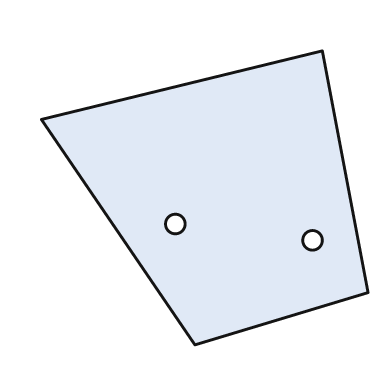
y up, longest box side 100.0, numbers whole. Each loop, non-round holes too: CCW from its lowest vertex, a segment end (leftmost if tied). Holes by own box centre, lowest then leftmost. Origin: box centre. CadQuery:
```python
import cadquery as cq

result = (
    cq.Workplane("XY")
    .moveTo(-3.0, -45.0)
    .lineTo(50.0, -29.0)
    .lineTo(36.0, 45.0)
    .lineTo(-50.0, 24.0)
    .close()
    .moveTo(33.0, -13.0)
    .circle(3.0)
    .moveTo(-9.0, -8.0)
    .circle(3.0)
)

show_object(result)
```